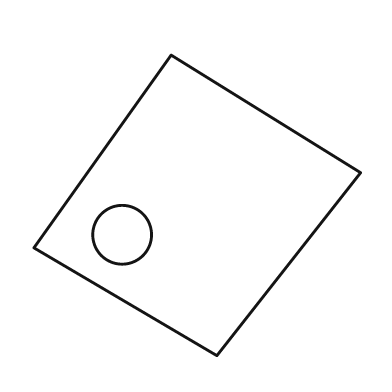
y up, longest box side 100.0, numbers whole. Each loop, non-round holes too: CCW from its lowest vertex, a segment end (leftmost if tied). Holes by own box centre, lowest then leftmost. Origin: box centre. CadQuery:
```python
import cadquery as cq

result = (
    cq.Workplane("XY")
    .moveTo(6.0, -46.0)
    .lineTo(50.0, 10.0)
    .lineTo(-8.0, 46.0)
    .lineTo(-50.0, -13.0)
    .close()
    .moveTo(-23.0, -9.0)
    .circle(9.0)
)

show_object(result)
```